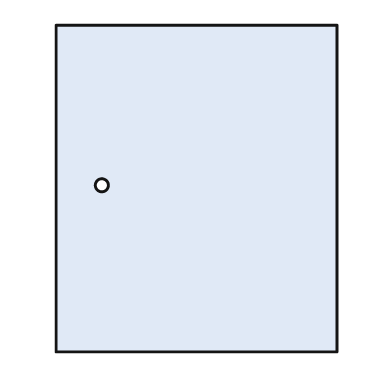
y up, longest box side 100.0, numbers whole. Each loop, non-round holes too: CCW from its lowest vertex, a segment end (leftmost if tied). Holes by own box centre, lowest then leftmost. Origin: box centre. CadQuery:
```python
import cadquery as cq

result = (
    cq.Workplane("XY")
    .moveTo(-43.0, -50.0)
    .lineTo(43.0, -50.0)
    .lineTo(43.0, 50.0)
    .lineTo(-43.0, 50.0)
    .close()
    .moveTo(-29.0, 1.0)
    .circle(2.0)
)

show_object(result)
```